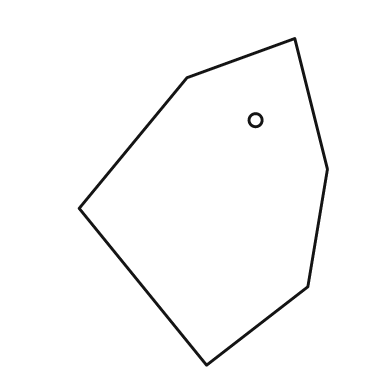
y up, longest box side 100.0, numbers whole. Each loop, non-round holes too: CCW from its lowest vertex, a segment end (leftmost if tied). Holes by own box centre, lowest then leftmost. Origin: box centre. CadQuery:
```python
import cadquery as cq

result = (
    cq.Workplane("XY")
    .moveTo(1.0, -50.0)
    .lineTo(32.0, -26.0)
    .lineTo(38.0, 10.0)
    .lineTo(28.0, 50.0)
    .lineTo(-5.0, 38.0)
    .lineTo(-38.0, -2.0)
    .close()
    .moveTo(16.0, 25.0)
    .circle(2.0)
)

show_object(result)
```